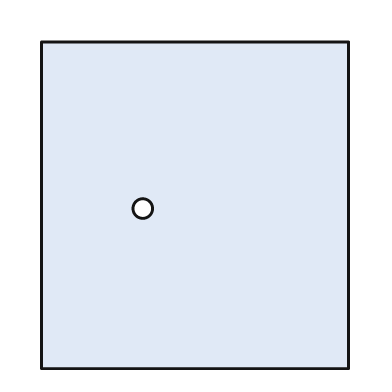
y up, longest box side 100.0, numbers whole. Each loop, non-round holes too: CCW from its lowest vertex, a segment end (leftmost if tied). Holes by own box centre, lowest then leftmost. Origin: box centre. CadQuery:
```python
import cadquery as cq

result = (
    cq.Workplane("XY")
    .moveTo(-47.0, -50.0)
    .lineTo(47.0, -50.0)
    .lineTo(47.0, 50.0)
    .lineTo(-47.0, 50.0)
    .close()
    .moveTo(-16.0, -1.0)
    .circle(3.0)
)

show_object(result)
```